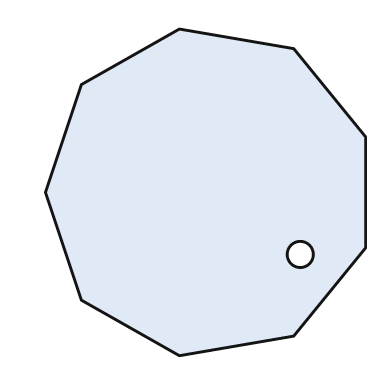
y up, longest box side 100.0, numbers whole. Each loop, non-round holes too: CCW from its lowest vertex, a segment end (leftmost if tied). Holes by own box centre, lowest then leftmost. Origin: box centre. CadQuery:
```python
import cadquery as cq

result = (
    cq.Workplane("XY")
    .moveTo(-8.0, -50.0)
    .lineTo(27.0, -44.0)
    .lineTo(49.0, -17.0)
    .lineTo(49.0, 17.0)
    .lineTo(27.0, 44.0)
    .lineTo(-8.0, 50.0)
    .lineTo(-38.0, 33.0)
    .lineTo(-49.0, 0.0)
    .lineTo(-38.0, -33.0)
    .close()
    .moveTo(29.0, -19.0)
    .circle(4.0)
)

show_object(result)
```